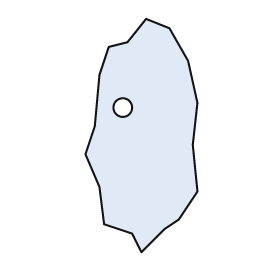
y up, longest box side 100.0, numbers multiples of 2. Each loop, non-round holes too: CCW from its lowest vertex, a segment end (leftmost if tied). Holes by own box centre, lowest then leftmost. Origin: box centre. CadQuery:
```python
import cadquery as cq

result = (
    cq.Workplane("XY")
    .moveTo(0.0, -50.0)
    .lineTo(10.0, -40.0)
    .lineTo(16.0, -36.0)
    .lineTo(24.0, -24.0)
    .lineTo(22.0, -4.0)
    .lineTo(24.0, 14.0)
    .lineTo(20.0, 32.0)
    .lineTo(12.0, 46.0)
    .lineTo(2.0, 50.0)
    .lineTo(-6.0, 40.0)
    .lineTo(-14.0, 38.0)
    .lineTo(-18.0, 26.0)
    .lineTo(-20.0, 4.0)
    .lineTo(-24.0, -8.0)
    .lineTo(-18.0, -22.0)
    .lineTo(-16.0, -38.0)
    .lineTo(-4.0, -42.0)
    .close()
    .moveTo(-8.0, 12.0)
    .circle(4.0)
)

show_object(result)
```